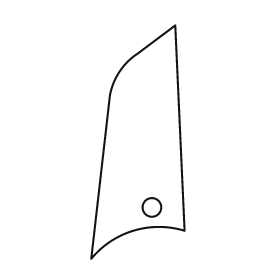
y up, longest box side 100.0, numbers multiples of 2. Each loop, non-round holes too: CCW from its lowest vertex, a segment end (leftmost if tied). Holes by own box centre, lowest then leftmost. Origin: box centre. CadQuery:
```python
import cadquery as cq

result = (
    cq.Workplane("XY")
    .moveTo(-20.0, -50.0)
    .threePointArc((-2.0, -38.0), (20.0, -38.0))
    .lineTo(16.0, 50.0)
    .lineTo(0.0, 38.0)
    .threePointArc((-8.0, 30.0), (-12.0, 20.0))
    .close()
    .moveTo(6.0, -28.0)
    .circle(4.0)
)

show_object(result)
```